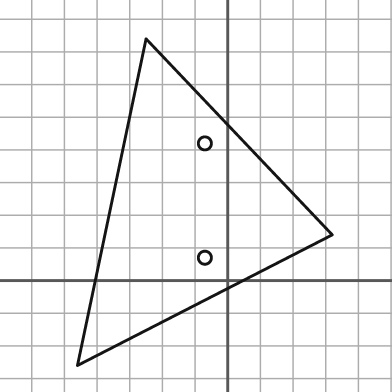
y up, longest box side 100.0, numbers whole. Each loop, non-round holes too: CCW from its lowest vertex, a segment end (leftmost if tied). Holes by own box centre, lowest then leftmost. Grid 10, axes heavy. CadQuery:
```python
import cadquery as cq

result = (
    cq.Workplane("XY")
    .moveTo(-46.0, -26.0)
    .lineTo(32.0, 14.0)
    .lineTo(-25.0, 74.0)
    .close()
    .moveTo(-7.0, 7.0)
    .circle(2.0)
    .moveTo(-7.0, 42.0)
    .circle(2.0)
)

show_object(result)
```